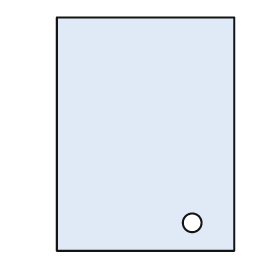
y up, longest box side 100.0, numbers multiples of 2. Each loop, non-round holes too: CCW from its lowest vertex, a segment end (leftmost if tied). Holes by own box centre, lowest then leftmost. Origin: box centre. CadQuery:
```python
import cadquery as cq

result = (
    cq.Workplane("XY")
    .moveTo(-38.0, -50.0)
    .lineTo(38.0, -50.0)
    .lineTo(38.0, 50.0)
    .lineTo(-38.0, 50.0)
    .close()
    .moveTo(20.0, -38.0)
    .circle(4.0)
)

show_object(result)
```